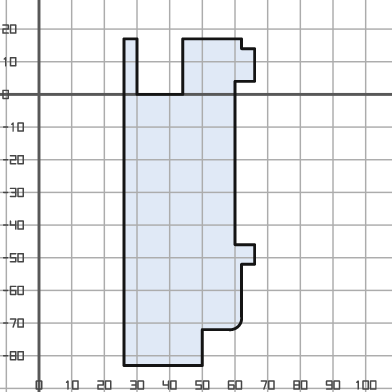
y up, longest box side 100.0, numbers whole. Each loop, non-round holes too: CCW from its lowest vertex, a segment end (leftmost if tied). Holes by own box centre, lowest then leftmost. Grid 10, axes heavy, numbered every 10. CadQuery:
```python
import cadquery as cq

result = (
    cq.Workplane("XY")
    .moveTo(26.0, -83.0)
    .lineTo(50.0, -83.0)
    .lineTo(50.0, -72.0)
    .lineTo(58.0, -72.0)
    .threePointArc((61.0, -71.0), (62.0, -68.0))
    .lineTo(62.0, -52.0)
    .lineTo(66.0, -52.0)
    .lineTo(66.0, -46.0)
    .lineTo(60.0, -46.0)
    .lineTo(60.0, 4.0)
    .lineTo(66.0, 4.0)
    .lineTo(66.0, 14.0)
    .lineTo(62.0, 14.0)
    .lineTo(62.0, 17.0)
    .lineTo(44.0, 17.0)
    .lineTo(44.0, 0.0)
    .lineTo(30.0, 0.0)
    .lineTo(30.0, 17.0)
    .lineTo(26.0, 17.0)
    .close()
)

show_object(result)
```